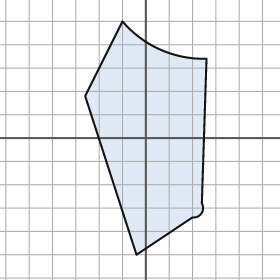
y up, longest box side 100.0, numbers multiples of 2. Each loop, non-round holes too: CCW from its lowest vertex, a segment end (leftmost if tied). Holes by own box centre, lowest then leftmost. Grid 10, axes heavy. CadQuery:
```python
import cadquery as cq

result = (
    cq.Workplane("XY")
    .moveTo(-4.0, -50.0)
    .lineTo(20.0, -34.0)
    .threePointArc((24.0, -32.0), (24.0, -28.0))
    .lineTo(26.0, 34.0)
    .threePointArc((6.0, 38.0), (-10.0, 50.0))
    .lineTo(-26.0, 18.0)
    .close()
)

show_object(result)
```